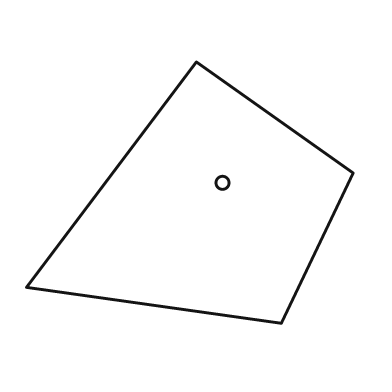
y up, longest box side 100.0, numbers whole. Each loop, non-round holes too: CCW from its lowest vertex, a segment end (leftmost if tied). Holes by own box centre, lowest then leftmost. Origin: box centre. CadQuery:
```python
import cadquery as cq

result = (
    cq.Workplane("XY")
    .moveTo(28.0, -40.0)
    .lineTo(50.0, 6.0)
    .lineTo(2.0, 40.0)
    .lineTo(-50.0, -29.0)
    .close()
    .moveTo(10.0, 3.0)
    .circle(2.0)
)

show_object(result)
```